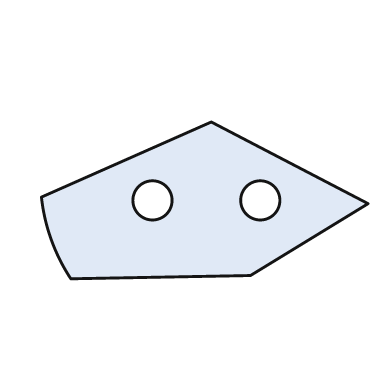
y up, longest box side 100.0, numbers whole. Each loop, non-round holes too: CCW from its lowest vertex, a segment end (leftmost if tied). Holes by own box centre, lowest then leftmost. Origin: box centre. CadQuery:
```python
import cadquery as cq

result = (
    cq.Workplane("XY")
    .moveTo(-41.0, -24.0)
    .lineTo(14.0, -23.0)
    .lineTo(50.0, -1.0)
    .lineTo(2.0, 24.0)
    .lineTo(-50.0, 1.0)
    .threePointArc((-47.0, -12.0), (-41.0, -24.0))
    .close()
    .moveTo(-16.0, 0.0)
    .circle(6.0)
    .moveTo(17.0, 0.0)
    .circle(6.0)
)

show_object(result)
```